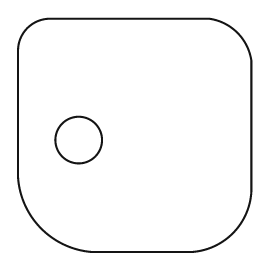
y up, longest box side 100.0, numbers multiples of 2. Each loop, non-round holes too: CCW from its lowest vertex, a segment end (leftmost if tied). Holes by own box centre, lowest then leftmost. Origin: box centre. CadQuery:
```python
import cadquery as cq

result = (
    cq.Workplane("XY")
    .moveTo(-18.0, -50.0)
    .lineTo(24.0, -50.0)
    .threePointArc((42.0, -42.0), (50.0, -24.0))
    .lineTo(50.0, 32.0)
    .threePointArc((44.0, 44.0), (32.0, 50.0))
    .lineTo(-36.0, 50.0)
    .threePointArc((-46.0, 46.0), (-50.0, 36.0))
    .lineTo(-50.0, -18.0)
    .threePointArc((-40.0, -40.0), (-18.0, -50.0))
    .close()
    .moveTo(-24.0, -2.0)
    .circle(10.0)
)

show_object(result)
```